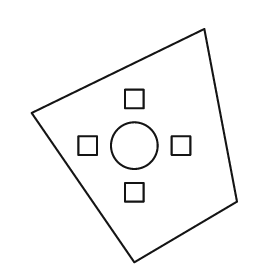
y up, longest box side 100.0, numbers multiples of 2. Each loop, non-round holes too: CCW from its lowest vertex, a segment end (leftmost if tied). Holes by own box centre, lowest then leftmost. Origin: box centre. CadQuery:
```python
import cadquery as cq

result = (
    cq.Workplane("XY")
    .moveTo(0.0, -50.0)
    .lineTo(44.0, -24.0)
    .lineTo(30.0, 50.0)
    .lineTo(-44.0, 14.0)
    .close()
    .moveTo(-4.0, -24.0)
    .lineTo(4.0, -24.0)
    .lineTo(4.0, -16.0)
    .lineTo(-4.0, -16.0)
    .close()
    .moveTo(-24.0, -4.0)
    .lineTo(-16.0, -4.0)
    .lineTo(-16.0, 4.0)
    .lineTo(-24.0, 4.0)
    .close()
    .moveTo(0.0, 0.0)
    .circle(10.0)
    .moveTo(16.0, -4.0)
    .lineTo(24.0, -4.0)
    .lineTo(24.0, 4.0)
    .lineTo(16.0, 4.0)
    .close()
    .moveTo(-4.0, 16.0)
    .lineTo(4.0, 16.0)
    .lineTo(4.0, 24.0)
    .lineTo(-4.0, 24.0)
    .close()
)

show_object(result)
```